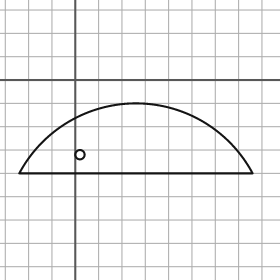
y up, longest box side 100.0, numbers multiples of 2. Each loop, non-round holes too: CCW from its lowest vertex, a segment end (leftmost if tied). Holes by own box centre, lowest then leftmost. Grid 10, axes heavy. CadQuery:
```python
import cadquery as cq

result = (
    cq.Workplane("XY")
    .moveTo(-24.0, -40.0)
    .lineTo(76.0, -40.0)
    .threePointArc((26.0, -10.0), (-24.0, -40.0))
    .close()
    .moveTo(2.0, -32.0)
    .circle(2.0)
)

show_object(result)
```